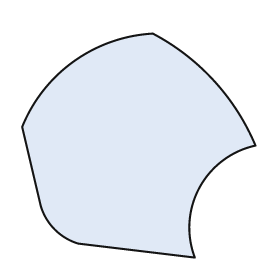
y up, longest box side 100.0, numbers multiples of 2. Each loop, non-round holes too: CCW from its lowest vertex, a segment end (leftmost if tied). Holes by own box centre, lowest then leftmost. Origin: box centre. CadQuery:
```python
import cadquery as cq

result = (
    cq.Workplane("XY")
    .moveTo(24.0, -48.0)
    .threePointArc((26.0, -18.0), (50.0, 0.0))
    .threePointArc((32.0, 28.0), (6.0, 48.0))
    .threePointArc((-28.0, 36.0), (-50.0, 8.0))
    .lineTo(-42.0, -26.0)
    .threePointArc((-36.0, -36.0), (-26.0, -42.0))
    .close()
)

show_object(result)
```